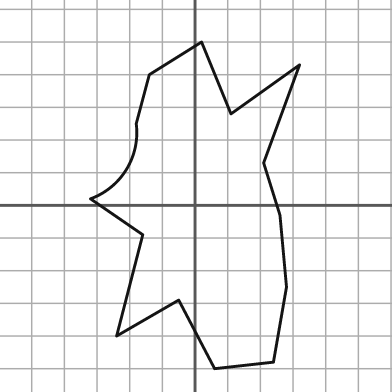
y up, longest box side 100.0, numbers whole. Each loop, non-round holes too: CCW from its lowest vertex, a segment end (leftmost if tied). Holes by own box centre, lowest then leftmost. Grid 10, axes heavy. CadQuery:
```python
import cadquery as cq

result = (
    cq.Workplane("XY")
    .moveTo(6.0, -50.0)
    .lineTo(24.0, -48.0)
    .lineTo(28.0, -25.0)
    .lineTo(26.0, -3.0)
    .lineTo(21.0, 13.0)
    .lineTo(32.0, 43.0)
    .lineTo(11.0, 28.0)
    .lineTo(2.0, 50.0)
    .lineTo(-14.0, 40.0)
    .lineTo(-18.0, 25.0)
    .threePointArc((-21.0, 11.0), (-32.0, 2.0))
    .lineTo(-16.0, -9.0)
    .lineTo(-24.0, -40.0)
    .lineTo(-5.0, -29.0)
    .close()
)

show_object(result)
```